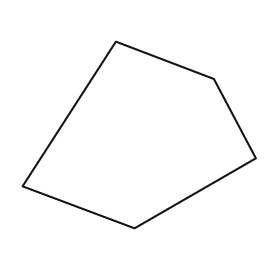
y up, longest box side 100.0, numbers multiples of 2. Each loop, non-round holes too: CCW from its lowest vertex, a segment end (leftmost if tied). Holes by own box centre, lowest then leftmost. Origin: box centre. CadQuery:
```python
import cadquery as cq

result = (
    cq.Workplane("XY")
    .moveTo(-2.0, -40.0)
    .lineTo(50.0, -10.0)
    .lineTo(32.0, 24.0)
    .lineTo(-10.0, 40.0)
    .lineTo(-50.0, -22.0)
    .close()
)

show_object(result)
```